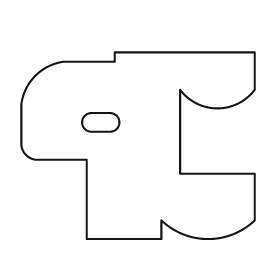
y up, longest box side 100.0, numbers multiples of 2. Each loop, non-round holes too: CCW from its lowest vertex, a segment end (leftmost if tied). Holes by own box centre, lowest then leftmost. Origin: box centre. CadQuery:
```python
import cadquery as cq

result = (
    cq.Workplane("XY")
    .moveTo(-22.0, -40.0)
    .lineTo(10.0, -40.0)
    .lineTo(10.0, -32.0)
    .threePointArc((30.0, -40.0), (50.0, -32.0))
    .lineTo(50.0, -12.0)
    .lineTo(18.0, -12.0)
    .lineTo(18.0, 24.0)
    .threePointArc((34.0, 16.0), (50.0, 24.0))
    .lineTo(50.0, 40.0)
    .lineTo(-10.0, 40.0)
    .lineTo(-10.0, 36.0)
    .lineTo(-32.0, 36.0)
    .threePointArc((-44.0, 30.0), (-50.0, 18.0))
    .lineTo(-50.0, 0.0)
    .threePointArc((-48.0, -4.0), (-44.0, -6.0))
    .lineTo(-22.0, -6.0)
    .close()
    .moveTo(-20.0, 6.0)
    .lineTo(-12.0, 6.0)
    .threePointArc((-8.0, 10.0), (-12.0, 14.0))
    .lineTo(-20.0, 14.0)
    .threePointArc((-24.0, 10.0), (-20.0, 6.0))
    .close()
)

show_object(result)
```